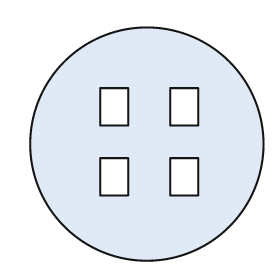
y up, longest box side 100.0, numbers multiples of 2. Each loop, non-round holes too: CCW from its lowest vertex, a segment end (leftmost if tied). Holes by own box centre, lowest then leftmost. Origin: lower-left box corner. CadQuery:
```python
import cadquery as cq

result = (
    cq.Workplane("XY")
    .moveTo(50.0, 50.0)
    .circle(50.0)
    .moveTo(30.0, 28.0)
    .lineTo(42.0, 28.0)
    .lineTo(42.0, 44.0)
    .lineTo(30.0, 44.0)
    .close()
    .moveTo(60.0, 28.0)
    .lineTo(72.0, 28.0)
    .lineTo(72.0, 44.0)
    .lineTo(60.0, 44.0)
    .close()
    .moveTo(30.0, 58.0)
    .lineTo(42.0, 58.0)
    .lineTo(42.0, 74.0)
    .lineTo(30.0, 74.0)
    .close()
    .moveTo(60.0, 58.0)
    .lineTo(72.0, 58.0)
    .lineTo(72.0, 74.0)
    .lineTo(60.0, 74.0)
    .close()
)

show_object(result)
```